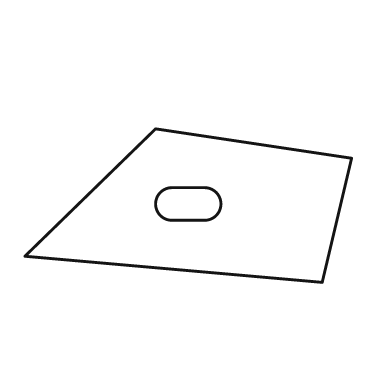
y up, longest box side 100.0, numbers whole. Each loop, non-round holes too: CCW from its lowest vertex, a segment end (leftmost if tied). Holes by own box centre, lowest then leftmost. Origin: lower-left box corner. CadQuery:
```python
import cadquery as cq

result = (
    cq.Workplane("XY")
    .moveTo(91.0, 0.0)
    .lineTo(100.0, 38.0)
    .lineTo(40.0, 47.0)
    .lineTo(0.0, 8.0)
    .close()
    .moveTo(45.0, 19.0)
    .lineTo(55.0, 19.0)
    .threePointArc((60.0, 24.0), (55.0, 29.0))
    .lineTo(45.0, 29.0)
    .threePointArc((40.0, 24.0), (45.0, 19.0))
    .close()
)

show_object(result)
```